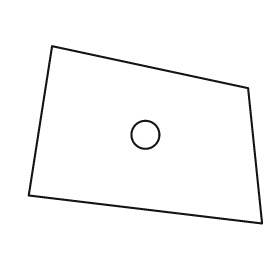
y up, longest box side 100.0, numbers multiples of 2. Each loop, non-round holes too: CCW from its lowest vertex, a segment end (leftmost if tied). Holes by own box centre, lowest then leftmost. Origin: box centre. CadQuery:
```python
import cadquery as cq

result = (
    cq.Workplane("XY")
    .moveTo(50.0, -38.0)
    .lineTo(44.0, 20.0)
    .lineTo(-40.0, 38.0)
    .lineTo(-50.0, -26.0)
    .close()
    .moveTo(0.0, 0.0)
    .circle(6.0)
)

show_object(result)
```